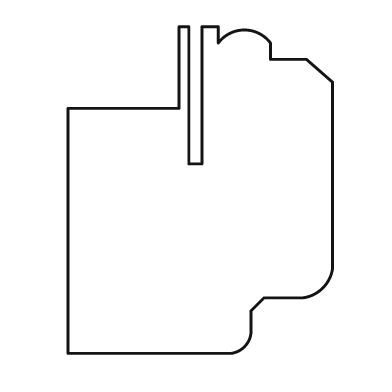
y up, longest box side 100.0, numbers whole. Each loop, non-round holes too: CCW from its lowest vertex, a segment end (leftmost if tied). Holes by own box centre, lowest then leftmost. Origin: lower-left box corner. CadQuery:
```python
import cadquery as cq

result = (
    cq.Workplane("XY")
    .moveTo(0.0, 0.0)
    .lineTo(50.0, 0.0)
    .threePointArc((54.0, 2.0), (56.0, 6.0))
    .lineTo(56.0, 13.0)
    .lineTo(60.0, 17.0)
    .lineTo(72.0, 17.0)
    .threePointArc((78.0, 20.0), (81.0, 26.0))
    .lineTo(81.0, 83.0)
    .lineTo(73.0, 90.0)
    .lineTo(62.0, 90.0)
    .lineTo(62.0, 95.0)
    .threePointArc((54.0, 99.0), (46.0, 95.0))
    .lineTo(46.0, 100.0)
    .lineTo(41.0, 100.0)
    .lineTo(41.0, 58.0)
    .lineTo(37.0, 58.0)
    .lineTo(37.0, 100.0)
    .lineTo(34.0, 100.0)
    .lineTo(34.0, 75.0)
    .lineTo(0.0, 75.0)
    .close()
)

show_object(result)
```